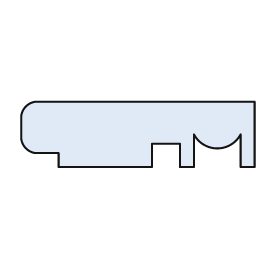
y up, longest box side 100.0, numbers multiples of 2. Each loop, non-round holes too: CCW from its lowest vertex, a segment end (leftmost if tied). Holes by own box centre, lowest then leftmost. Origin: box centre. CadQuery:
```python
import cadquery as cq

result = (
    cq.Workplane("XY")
    .moveTo(-34.0, -14.0)
    .lineTo(6.0, -14.0)
    .lineTo(6.0, -4.0)
    .lineTo(18.0, -4.0)
    .lineTo(18.0, -14.0)
    .lineTo(24.0, -14.0)
    .lineTo(24.0, 0.0)
    .threePointArc((34.0, -6.0), (44.0, 0.0))
    .lineTo(44.0, -14.0)
    .lineTo(50.0, -14.0)
    .lineTo(50.0, 14.0)
    .lineTo(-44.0, 14.0)
    .threePointArc((-48.0, 12.0), (-50.0, 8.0))
    .lineTo(-50.0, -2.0)
    .threePointArc((-48.0, -6.0), (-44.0, -8.0))
    .lineTo(-34.0, -8.0)
    .close()
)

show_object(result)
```